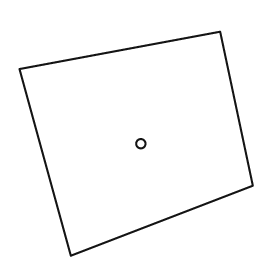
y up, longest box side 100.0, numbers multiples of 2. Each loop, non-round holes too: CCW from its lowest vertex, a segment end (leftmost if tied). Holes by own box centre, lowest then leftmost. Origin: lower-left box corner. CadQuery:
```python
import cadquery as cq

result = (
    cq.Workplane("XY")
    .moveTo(22.0, 0.0)
    .lineTo(100.0, 30.0)
    .lineTo(86.0, 96.0)
    .lineTo(0.0, 80.0)
    .close()
    .moveTo(52.0, 48.0)
    .circle(2.0)
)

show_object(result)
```